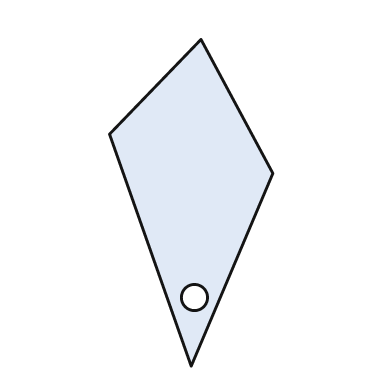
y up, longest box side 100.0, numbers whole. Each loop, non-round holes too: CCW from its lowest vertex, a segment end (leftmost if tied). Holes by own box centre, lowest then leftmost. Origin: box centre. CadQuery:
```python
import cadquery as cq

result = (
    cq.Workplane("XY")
    .moveTo(0.0, -50.0)
    .lineTo(25.0, 9.0)
    .lineTo(3.0, 50.0)
    .lineTo(-25.0, 21.0)
    .close()
    .moveTo(1.0, -29.0)
    .circle(4.0)
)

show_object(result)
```